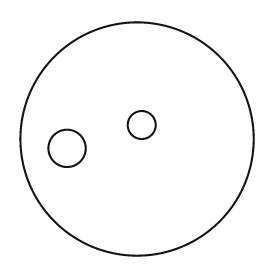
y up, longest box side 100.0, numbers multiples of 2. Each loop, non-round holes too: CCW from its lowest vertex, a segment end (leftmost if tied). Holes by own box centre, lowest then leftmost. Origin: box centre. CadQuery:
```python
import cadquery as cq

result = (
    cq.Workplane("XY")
    .moveTo(0.0, 0.0)
    .circle(50.0)
    .moveTo(-30.0, -4.0)
    .circle(8.0)
    .moveTo(2.0, 6.0)
    .circle(6.0)
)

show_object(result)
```